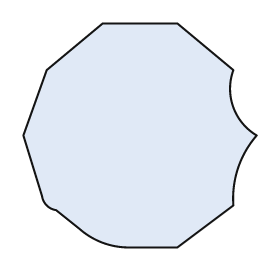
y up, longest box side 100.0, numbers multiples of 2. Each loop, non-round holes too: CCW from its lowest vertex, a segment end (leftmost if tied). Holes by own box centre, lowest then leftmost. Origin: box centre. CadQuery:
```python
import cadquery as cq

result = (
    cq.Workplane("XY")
    .moveTo(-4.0, -48.0)
    .lineTo(16.0, -48.0)
    .lineTo(40.0, -30.0)
    .threePointArc((42.0, -14.0), (50.0, 0.0))
    .threePointArc((40.0, 12.0), (40.0, 28.0))
    .lineTo(16.0, 48.0)
    .lineTo(-16.0, 48.0)
    .lineTo(-40.0, 28.0)
    .lineTo(-50.0, 0.0)
    .lineTo(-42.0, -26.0)
    .threePointArc((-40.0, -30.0), (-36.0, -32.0))
    .lineTo(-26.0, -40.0)
    .threePointArc((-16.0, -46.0), (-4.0, -48.0))
    .close()
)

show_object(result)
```